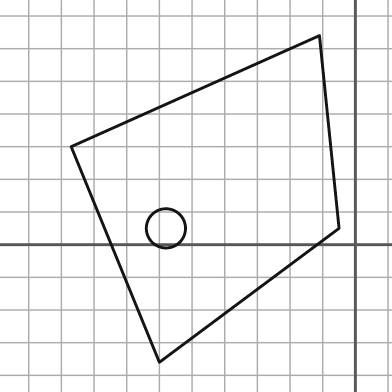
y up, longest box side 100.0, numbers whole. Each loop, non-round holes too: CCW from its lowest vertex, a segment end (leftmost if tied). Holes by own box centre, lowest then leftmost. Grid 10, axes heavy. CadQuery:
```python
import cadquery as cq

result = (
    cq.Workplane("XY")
    .moveTo(-60.0, -36.0)
    .lineTo(-5.0, 5.0)
    .lineTo(-11.0, 64.0)
    .lineTo(-87.0, 30.0)
    .close()
    .moveTo(-58.0, 5.0)
    .circle(6.0)
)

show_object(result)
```